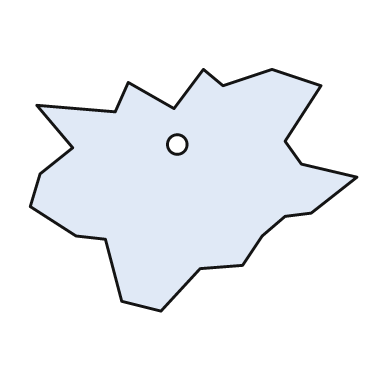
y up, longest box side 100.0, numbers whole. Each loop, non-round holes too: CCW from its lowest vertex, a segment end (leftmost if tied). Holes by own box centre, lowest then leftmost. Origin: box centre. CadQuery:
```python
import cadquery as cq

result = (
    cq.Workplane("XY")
    .moveTo(-10.0, -37.0)
    .lineTo(2.0, -24.0)
    .lineTo(15.0, -23.0)
    .lineTo(21.0, -14.0)
    .lineTo(28.0, -8.0)
    .lineTo(36.0, -7.0)
    .lineTo(50.0, 4.0)
    .lineTo(33.0, 8.0)
    .lineTo(28.0, 15.0)
    .lineTo(39.0, 32.0)
    .lineTo(24.0, 37.0)
    .lineTo(9.0, 32.0)
    .lineTo(3.0, 37.0)
    .lineTo(-6.0, 25.0)
    .lineTo(-20.0, 33.0)
    .lineTo(-24.0, 24.0)
    .lineTo(-48.0, 26.0)
    .lineTo(-37.0, 13.0)
    .lineTo(-47.0, 5.0)
    .lineTo(-50.0, -5.0)
    .lineTo(-36.0, -14.0)
    .lineTo(-27.0, -15.0)
    .lineTo(-22.0, -34.0)
    .close()
    .moveTo(-5.0, 14.0)
    .circle(3.0)
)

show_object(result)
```